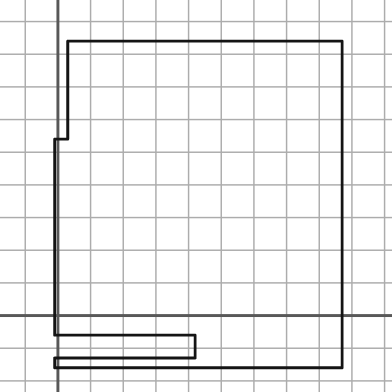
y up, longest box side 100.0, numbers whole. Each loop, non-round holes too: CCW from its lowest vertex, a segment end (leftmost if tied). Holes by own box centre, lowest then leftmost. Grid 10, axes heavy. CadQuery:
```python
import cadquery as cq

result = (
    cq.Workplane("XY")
    .moveTo(-1.0, -16.0)
    .lineTo(87.0, -16.0)
    .lineTo(87.0, 84.0)
    .lineTo(3.0, 84.0)
    .lineTo(3.0, 54.0)
    .lineTo(-1.0, 54.0)
    .lineTo(-1.0, -6.0)
    .lineTo(42.0, -6.0)
    .lineTo(42.0, -13.0)
    .lineTo(-1.0, -13.0)
    .close()
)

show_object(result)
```